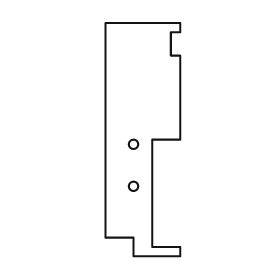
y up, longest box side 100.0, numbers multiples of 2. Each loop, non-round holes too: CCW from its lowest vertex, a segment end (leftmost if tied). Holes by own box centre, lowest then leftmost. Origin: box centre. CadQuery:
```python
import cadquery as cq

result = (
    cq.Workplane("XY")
    .moveTo(-4.0, -50.0)
    .lineTo(16.0, -50.0)
    .lineTo(16.0, -46.0)
    .lineTo(4.0, -46.0)
    .lineTo(4.0, 0.0)
    .lineTo(16.0, 0.0)
    .lineTo(16.0, 36.0)
    .lineTo(12.0, 36.0)
    .lineTo(12.0, 46.0)
    .lineTo(16.0, 46.0)
    .lineTo(16.0, 50.0)
    .lineTo(-16.0, 50.0)
    .lineTo(-16.0, -42.0)
    .lineTo(-4.0, -42.0)
    .close()
    .moveTo(-4.0, -20.0)
    .circle(2.0)
    .moveTo(-4.0, -2.0)
    .circle(2.0)
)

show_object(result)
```